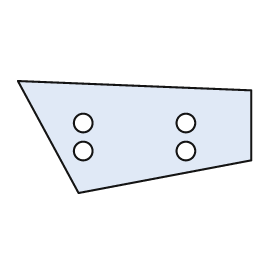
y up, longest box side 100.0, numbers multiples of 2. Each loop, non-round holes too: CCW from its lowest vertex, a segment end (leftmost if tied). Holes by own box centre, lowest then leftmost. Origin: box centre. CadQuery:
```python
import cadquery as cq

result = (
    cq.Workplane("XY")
    .moveTo(-24.0, -24.0)
    .lineTo(50.0, -10.0)
    .lineTo(50.0, 20.0)
    .lineTo(-50.0, 24.0)
    .close()
    .moveTo(-22.0, -6.0)
    .circle(4.0)
    .moveTo(22.0, -6.0)
    .circle(4.0)
    .moveTo(-22.0, 6.0)
    .circle(4.0)
    .moveTo(22.0, 6.0)
    .circle(4.0)
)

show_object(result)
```